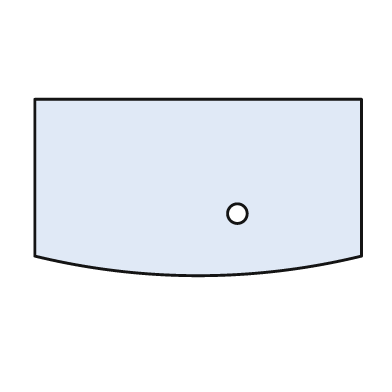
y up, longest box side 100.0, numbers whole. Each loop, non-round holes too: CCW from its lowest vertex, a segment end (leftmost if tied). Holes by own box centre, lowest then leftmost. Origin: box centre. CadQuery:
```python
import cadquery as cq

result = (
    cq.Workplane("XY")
    .moveTo(-50.0, -21.0)
    .threePointArc((0.0, -27.0), (50.0, -21.0))
    .lineTo(50.0, 27.0)
    .lineTo(-50.0, 27.0)
    .close()
    .moveTo(12.0, -8.0)
    .circle(3.0)
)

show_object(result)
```